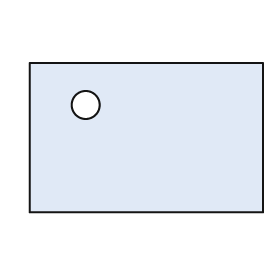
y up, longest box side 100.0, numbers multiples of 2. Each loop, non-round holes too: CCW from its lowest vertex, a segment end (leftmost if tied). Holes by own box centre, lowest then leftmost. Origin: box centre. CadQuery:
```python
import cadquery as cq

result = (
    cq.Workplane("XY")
    .moveTo(-50.0, -32.0)
    .lineTo(50.0, -32.0)
    .lineTo(50.0, 32.0)
    .lineTo(-50.0, 32.0)
    .close()
    .moveTo(-26.0, 14.0)
    .circle(6.0)
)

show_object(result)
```